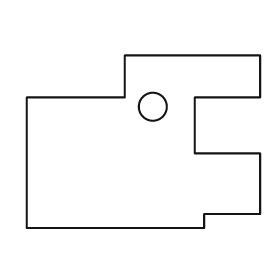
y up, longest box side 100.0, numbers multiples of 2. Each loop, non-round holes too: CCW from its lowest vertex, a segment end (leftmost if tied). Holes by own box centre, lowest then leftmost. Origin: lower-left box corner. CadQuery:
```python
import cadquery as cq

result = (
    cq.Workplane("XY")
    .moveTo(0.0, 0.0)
    .lineTo(76.0, 0.0)
    .lineTo(76.0, 6.0)
    .lineTo(100.0, 6.0)
    .lineTo(100.0, 32.0)
    .lineTo(72.0, 32.0)
    .lineTo(72.0, 56.0)
    .lineTo(100.0, 56.0)
    .lineTo(100.0, 74.0)
    .lineTo(42.0, 74.0)
    .lineTo(42.0, 56.0)
    .lineTo(0.0, 56.0)
    .close()
    .moveTo(54.0, 52.0)
    .circle(6.0)
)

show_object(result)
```